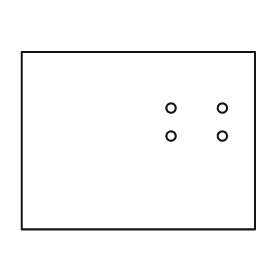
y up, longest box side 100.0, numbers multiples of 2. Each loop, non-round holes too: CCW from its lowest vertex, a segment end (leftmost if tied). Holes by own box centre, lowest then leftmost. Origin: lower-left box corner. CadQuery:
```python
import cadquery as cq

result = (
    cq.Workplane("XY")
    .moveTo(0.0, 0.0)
    .lineTo(100.0, 0.0)
    .lineTo(100.0, 76.0)
    .lineTo(0.0, 76.0)
    .close()
    .moveTo(64.0, 40.0)
    .circle(2.0)
    .moveTo(86.0, 40.0)
    .circle(2.0)
    .moveTo(64.0, 52.0)
    .circle(2.0)
    .moveTo(86.0, 52.0)
    .circle(2.0)
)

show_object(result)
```